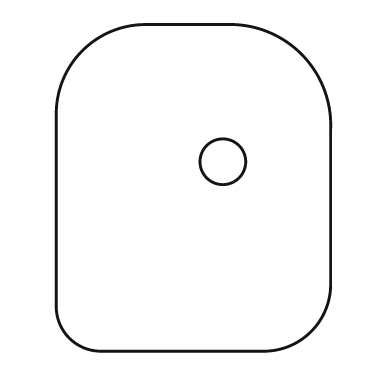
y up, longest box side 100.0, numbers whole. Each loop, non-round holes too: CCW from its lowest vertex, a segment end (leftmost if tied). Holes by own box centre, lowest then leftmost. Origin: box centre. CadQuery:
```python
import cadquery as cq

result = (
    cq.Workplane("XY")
    .moveTo(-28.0, -50.0)
    .lineTo(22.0, -50.0)
    .threePointArc((36.0, -44.0), (42.0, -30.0))
    .lineTo(42.0, 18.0)
    .threePointArc((33.0, 41.0), (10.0, 50.0))
    .lineTo(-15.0, 50.0)
    .threePointArc((-34.0, 42.0), (-42.0, 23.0))
    .lineTo(-42.0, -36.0)
    .threePointArc((-38.0, -46.0), (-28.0, -50.0))
    .close()
    .moveTo(9.0, 8.0)
    .circle(7.0)
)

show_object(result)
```